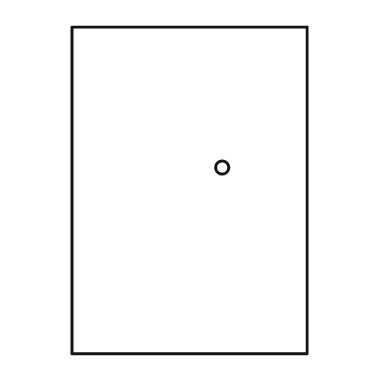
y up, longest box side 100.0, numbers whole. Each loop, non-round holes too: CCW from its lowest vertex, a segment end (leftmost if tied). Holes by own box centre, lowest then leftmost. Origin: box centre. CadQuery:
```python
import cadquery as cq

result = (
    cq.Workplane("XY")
    .moveTo(-36.0, -50.0)
    .lineTo(36.0, -50.0)
    .lineTo(36.0, 50.0)
    .lineTo(-36.0, 50.0)
    .close()
    .moveTo(10.0, 7.0)
    .circle(2.0)
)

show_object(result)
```